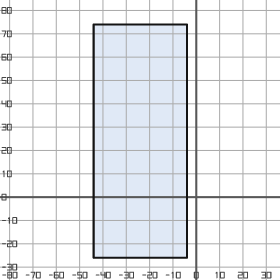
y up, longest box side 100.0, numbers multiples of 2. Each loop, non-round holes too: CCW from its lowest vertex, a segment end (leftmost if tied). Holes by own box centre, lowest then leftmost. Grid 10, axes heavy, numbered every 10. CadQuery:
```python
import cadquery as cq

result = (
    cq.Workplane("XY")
    .moveTo(-44.0, -26.0)
    .lineTo(-4.0, -26.0)
    .lineTo(-4.0, 74.0)
    .lineTo(-44.0, 74.0)
    .close()
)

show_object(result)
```